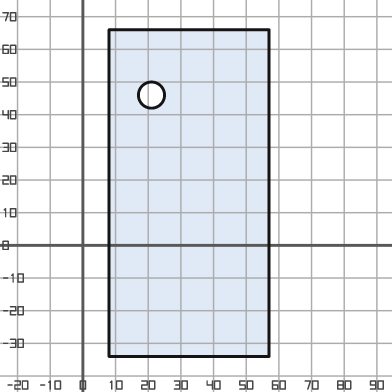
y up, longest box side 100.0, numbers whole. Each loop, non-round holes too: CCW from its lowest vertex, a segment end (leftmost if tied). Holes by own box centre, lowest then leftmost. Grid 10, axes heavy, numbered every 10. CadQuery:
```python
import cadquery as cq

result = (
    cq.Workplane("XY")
    .moveTo(8.0, -34.0)
    .lineTo(57.0, -34.0)
    .lineTo(57.0, 66.0)
    .lineTo(8.0, 66.0)
    .close()
    .moveTo(21.0, 46.0)
    .circle(4.0)
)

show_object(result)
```